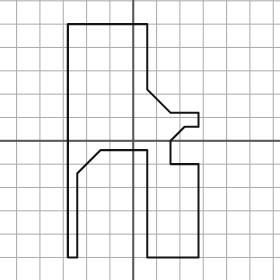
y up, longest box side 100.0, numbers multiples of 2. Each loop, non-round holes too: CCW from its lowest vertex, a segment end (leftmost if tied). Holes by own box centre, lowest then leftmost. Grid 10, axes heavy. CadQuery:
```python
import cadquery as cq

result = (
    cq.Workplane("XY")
    .moveTo(-28.0, -50.0)
    .lineTo(-24.0, -50.0)
    .lineTo(-24.0, -14.0)
    .lineTo(-14.0, -4.0)
    .lineTo(6.0, -4.0)
    .lineTo(6.0, -50.0)
    .lineTo(28.0, -50.0)
    .lineTo(28.0, -10.0)
    .lineTo(16.0, -10.0)
    .lineTo(16.0, 0.0)
    .lineTo(22.0, 6.0)
    .lineTo(28.0, 6.0)
    .lineTo(28.0, 12.0)
    .lineTo(16.0, 12.0)
    .lineTo(6.0, 22.0)
    .lineTo(6.0, 50.0)
    .lineTo(-28.0, 50.0)
    .close()
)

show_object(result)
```